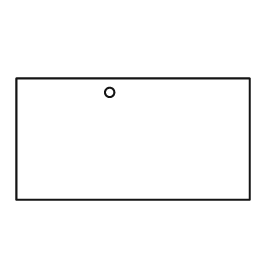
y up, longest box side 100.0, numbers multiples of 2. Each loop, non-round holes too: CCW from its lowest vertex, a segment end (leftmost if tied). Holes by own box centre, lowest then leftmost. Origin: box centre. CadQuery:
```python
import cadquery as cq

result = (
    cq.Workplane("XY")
    .moveTo(-50.0, -26.0)
    .lineTo(50.0, -26.0)
    .lineTo(50.0, 26.0)
    .lineTo(-50.0, 26.0)
    .close()
    .moveTo(-10.0, 20.0)
    .circle(2.0)
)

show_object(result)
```